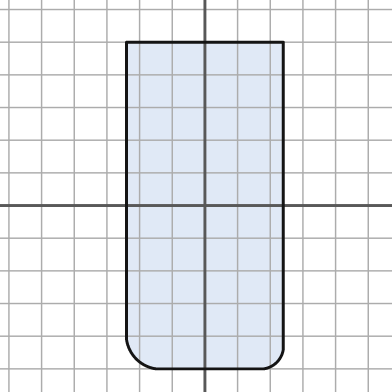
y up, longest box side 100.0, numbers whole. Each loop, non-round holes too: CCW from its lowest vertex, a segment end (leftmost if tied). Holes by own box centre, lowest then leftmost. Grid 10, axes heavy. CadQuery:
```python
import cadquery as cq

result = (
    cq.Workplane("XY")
    .moveTo(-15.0, -50.0)
    .lineTo(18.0, -50.0)
    .threePointArc((22.0, -48.0), (24.0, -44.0))
    .lineTo(24.0, 50.0)
    .lineTo(-24.0, 50.0)
    .lineTo(-24.0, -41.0)
    .threePointArc((-21.0, -47.0), (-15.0, -50.0))
    .close()
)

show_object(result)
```